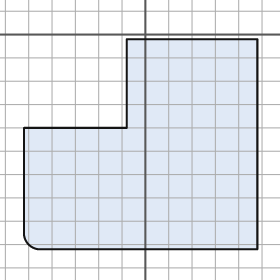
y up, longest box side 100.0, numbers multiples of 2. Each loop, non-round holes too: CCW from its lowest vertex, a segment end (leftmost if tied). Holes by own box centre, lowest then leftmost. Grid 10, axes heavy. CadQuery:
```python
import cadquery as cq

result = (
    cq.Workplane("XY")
    .moveTo(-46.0, -92.0)
    .lineTo(48.0, -92.0)
    .lineTo(48.0, -2.0)
    .lineTo(-8.0, -2.0)
    .lineTo(-8.0, -40.0)
    .lineTo(-52.0, -40.0)
    .lineTo(-52.0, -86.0)
    .threePointArc((-50.0, -90.0), (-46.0, -92.0))
    .close()
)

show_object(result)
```